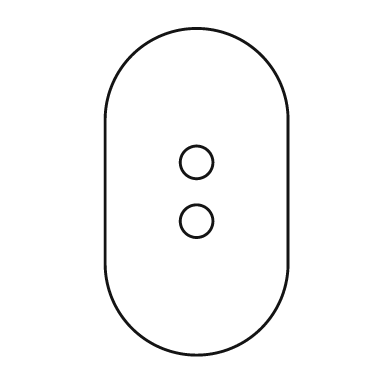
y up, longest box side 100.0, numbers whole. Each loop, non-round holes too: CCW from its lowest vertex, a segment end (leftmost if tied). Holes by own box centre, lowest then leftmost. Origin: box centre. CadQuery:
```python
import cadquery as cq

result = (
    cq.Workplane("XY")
    .moveTo(-28.0, -22.0)
    .threePointArc((0.0, -50.0), (28.0, -22.0))
    .lineTo(28.0, 22.0)
    .threePointArc((0.0, 50.0), (-28.0, 22.0))
    .close()
    .moveTo(0.0, -9.0)
    .circle(5.0)
    .moveTo(0.0, 9.0)
    .circle(5.0)
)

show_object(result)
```